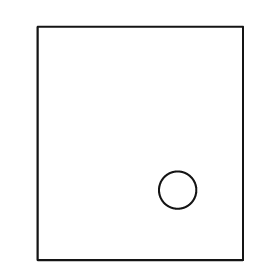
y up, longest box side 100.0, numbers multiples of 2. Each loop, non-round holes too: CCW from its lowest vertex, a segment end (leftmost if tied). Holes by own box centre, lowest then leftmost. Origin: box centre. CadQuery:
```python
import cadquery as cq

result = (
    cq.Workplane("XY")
    .moveTo(-44.0, -50.0)
    .lineTo(44.0, -50.0)
    .lineTo(44.0, 50.0)
    .lineTo(-44.0, 50.0)
    .close()
    .moveTo(16.0, -20.0)
    .circle(8.0)
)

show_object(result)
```